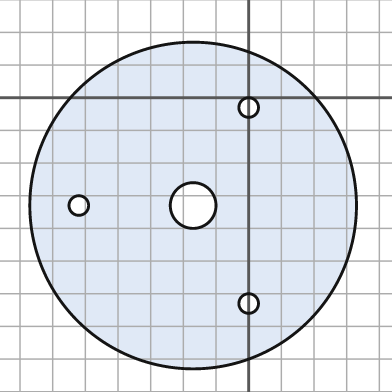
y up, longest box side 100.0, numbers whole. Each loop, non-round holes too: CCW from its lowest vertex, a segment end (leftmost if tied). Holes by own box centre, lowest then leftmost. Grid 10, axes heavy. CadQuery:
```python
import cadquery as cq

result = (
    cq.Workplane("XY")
    .moveTo(-17.0, -33.0)
    .circle(50.0)
    .moveTo(0.0, -63.0)
    .circle(3.0)
    .moveTo(-52.0, -33.0)
    .circle(3.0)
    .moveTo(-17.0, -33.0)
    .circle(7.0)
    .moveTo(0.0, -3.0)
    .circle(3.0)
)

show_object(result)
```